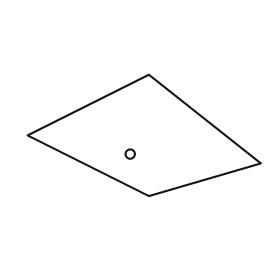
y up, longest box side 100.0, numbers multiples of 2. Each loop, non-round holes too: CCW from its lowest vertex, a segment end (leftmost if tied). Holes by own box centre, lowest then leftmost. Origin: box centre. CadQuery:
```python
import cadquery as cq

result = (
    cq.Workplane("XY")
    .moveTo(2.0, -26.0)
    .lineTo(50.0, -12.0)
    .lineTo(2.0, 26.0)
    .lineTo(-50.0, 0.0)
    .close()
    .moveTo(-6.0, -8.0)
    .circle(2.0)
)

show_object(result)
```